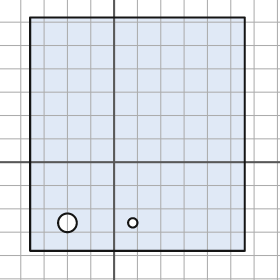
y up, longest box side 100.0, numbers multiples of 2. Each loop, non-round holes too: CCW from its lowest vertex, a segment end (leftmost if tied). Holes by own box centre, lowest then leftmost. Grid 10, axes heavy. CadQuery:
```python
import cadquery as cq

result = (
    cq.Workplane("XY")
    .moveTo(-36.0, -38.0)
    .lineTo(56.0, -38.0)
    .lineTo(56.0, 62.0)
    .lineTo(-36.0, 62.0)
    .close()
    .moveTo(-20.0, -26.0)
    .circle(4.0)
    .moveTo(8.0, -26.0)
    .circle(2.0)
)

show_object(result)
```